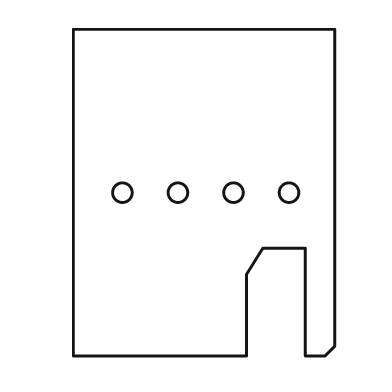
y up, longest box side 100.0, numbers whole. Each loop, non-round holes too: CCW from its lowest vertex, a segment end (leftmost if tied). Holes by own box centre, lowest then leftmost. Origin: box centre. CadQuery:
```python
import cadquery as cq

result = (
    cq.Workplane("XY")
    .moveTo(-40.0, -50.0)
    .lineTo(13.0, -50.0)
    .lineTo(13.0, -25.0)
    .lineTo(18.0, -17.0)
    .lineTo(31.0, -17.0)
    .lineTo(31.0, -50.0)
    .lineTo(37.0, -50.0)
    .lineTo(40.0, -47.0)
    .lineTo(40.0, 50.0)
    .lineTo(-40.0, 50.0)
    .close()
    .moveTo(-25.0, 0.0)
    .circle(3.0)
    .moveTo(-8.0, 0.0)
    .circle(3.0)
    .moveTo(9.0, 0.0)
    .circle(3.0)
    .moveTo(26.0, 0.0)
    .circle(3.0)
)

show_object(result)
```